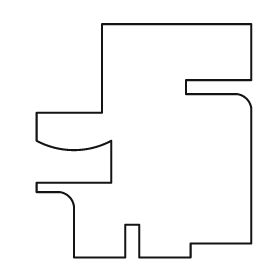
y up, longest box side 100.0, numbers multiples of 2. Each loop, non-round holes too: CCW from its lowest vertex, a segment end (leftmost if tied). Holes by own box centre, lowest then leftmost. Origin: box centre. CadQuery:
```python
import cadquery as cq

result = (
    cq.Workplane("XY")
    .moveTo(-30.0, -50.0)
    .lineTo(-8.0, -50.0)
    .lineTo(-8.0, -36.0)
    .lineTo(-2.0, -36.0)
    .lineTo(-2.0, -50.0)
    .lineTo(20.0, -50.0)
    .lineTo(20.0, -44.0)
    .lineTo(46.0, -44.0)
    .lineTo(46.0, 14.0)
    .threePointArc((44.0, 18.0), (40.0, 20.0))
    .lineTo(18.0, 20.0)
    .lineTo(18.0, 26.0)
    .lineTo(46.0, 26.0)
    .lineTo(46.0, 50.0)
    .lineTo(-18.0, 50.0)
    .lineTo(-18.0, 12.0)
    .lineTo(-46.0, 12.0)
    .lineTo(-46.0, 0.0)
    .threePointArc((-30.0, -4.0), (-14.0, 0.0))
    .lineTo(-14.0, -18.0)
    .lineTo(-46.0, -18.0)
    .lineTo(-46.0, -22.0)
    .lineTo(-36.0, -22.0)
    .threePointArc((-32.0, -24.0), (-30.0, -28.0))
    .close()
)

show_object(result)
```